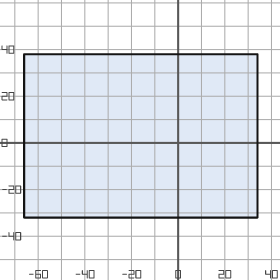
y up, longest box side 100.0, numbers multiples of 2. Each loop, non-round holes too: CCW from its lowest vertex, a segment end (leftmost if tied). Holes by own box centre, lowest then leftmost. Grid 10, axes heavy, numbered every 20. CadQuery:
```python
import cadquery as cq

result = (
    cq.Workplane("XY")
    .moveTo(-66.0, -32.0)
    .lineTo(34.0, -32.0)
    .lineTo(34.0, 38.0)
    .lineTo(-66.0, 38.0)
    .close()
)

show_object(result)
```